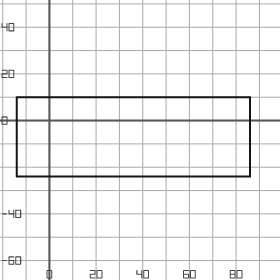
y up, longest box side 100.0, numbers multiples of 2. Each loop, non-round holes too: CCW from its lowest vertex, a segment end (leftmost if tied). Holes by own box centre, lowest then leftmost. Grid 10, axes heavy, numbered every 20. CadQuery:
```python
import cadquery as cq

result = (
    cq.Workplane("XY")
    .moveTo(-14.0, -24.0)
    .lineTo(86.0, -24.0)
    .lineTo(86.0, 10.0)
    .lineTo(-14.0, 10.0)
    .close()
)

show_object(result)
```